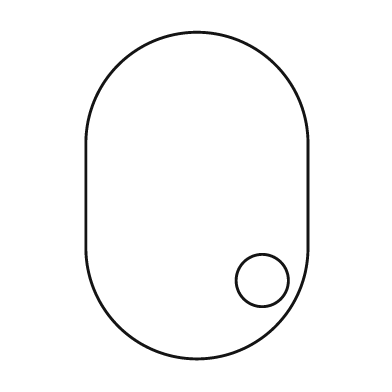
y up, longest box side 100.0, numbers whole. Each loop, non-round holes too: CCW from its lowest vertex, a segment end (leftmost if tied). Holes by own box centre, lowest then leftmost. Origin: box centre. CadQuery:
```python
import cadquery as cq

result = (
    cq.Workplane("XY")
    .moveTo(-34.0, -16.0)
    .threePointArc((0.0, -50.0), (34.0, -16.0))
    .lineTo(34.0, 16.0)
    .threePointArc((0.0, 50.0), (-34.0, 16.0))
    .close()
    .moveTo(20.0, -26.0)
    .circle(8.0)
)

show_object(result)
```